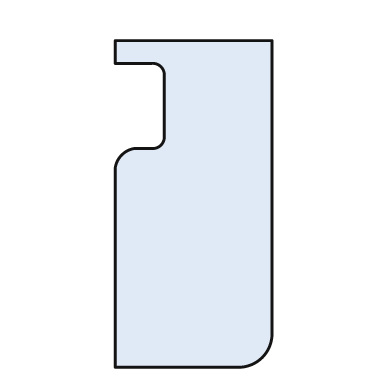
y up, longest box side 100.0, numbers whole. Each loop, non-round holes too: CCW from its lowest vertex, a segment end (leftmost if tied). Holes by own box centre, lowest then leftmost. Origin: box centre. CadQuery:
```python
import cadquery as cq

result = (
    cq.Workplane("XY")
    .moveTo(-24.0, -50.0)
    .lineTo(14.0, -50.0)
    .threePointArc((21.0, -47.0), (24.0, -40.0))
    .lineTo(24.0, 50.0)
    .lineTo(-24.0, 50.0)
    .lineTo(-24.0, 43.0)
    .lineTo(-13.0, 43.0)
    .threePointArc((-10.0, 42.0), (-9.0, 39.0))
    .lineTo(-9.0, 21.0)
    .threePointArc((-10.0, 18.0), (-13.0, 17.0))
    .lineTo(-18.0, 17.0)
    .threePointArc((-22.0, 15.0), (-24.0, 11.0))
    .close()
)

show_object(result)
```